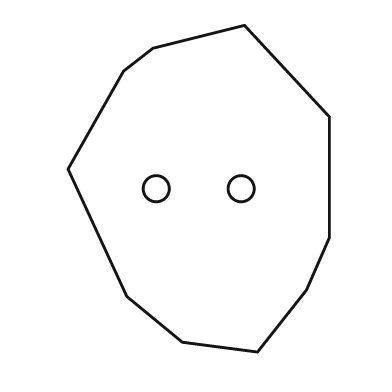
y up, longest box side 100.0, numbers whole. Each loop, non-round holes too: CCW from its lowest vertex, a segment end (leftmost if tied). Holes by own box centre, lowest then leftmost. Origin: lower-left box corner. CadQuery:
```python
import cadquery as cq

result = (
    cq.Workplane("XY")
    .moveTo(58.0, 0.0)
    .lineTo(73.0, 19.0)
    .lineTo(80.0, 35.0)
    .lineTo(80.0, 72.0)
    .lineTo(54.0, 100.0)
    .lineTo(26.0, 93.0)
    .lineTo(17.0, 86.0)
    .lineTo(0.0, 56.0)
    .lineTo(18.0, 17.0)
    .lineTo(35.0, 3.0)
    .close()
    .moveTo(27.0, 50.0)
    .circle(4.0)
    .moveTo(53.0, 50.0)
    .circle(4.0)
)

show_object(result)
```